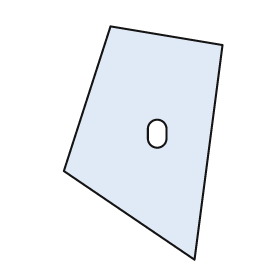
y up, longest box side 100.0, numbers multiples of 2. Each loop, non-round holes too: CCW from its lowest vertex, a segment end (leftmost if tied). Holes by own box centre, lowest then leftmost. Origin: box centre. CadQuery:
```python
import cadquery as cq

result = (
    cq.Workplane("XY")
    .moveTo(22.0, -50.0)
    .lineTo(34.0, 42.0)
    .lineTo(-14.0, 50.0)
    .lineTo(-34.0, -12.0)
    .close()
    .moveTo(2.0, 2.0)
    .threePointArc((6.0, -2.0), (10.0, 2.0))
    .lineTo(10.0, 6.0)
    .threePointArc((6.0, 10.0), (2.0, 6.0))
    .close()
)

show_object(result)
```